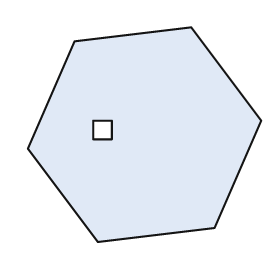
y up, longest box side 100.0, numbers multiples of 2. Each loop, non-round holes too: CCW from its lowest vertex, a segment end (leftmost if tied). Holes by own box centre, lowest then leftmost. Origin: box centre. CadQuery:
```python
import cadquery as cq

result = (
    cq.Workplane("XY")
    .moveTo(-20.0, -46.0)
    .lineTo(30.0, -40.0)
    .lineTo(50.0, 6.0)
    .lineTo(20.0, 46.0)
    .lineTo(-30.0, 40.0)
    .lineTo(-50.0, -6.0)
    .close()
    .moveTo(-22.0, -2.0)
    .lineTo(-14.0, -2.0)
    .lineTo(-14.0, 6.0)
    .lineTo(-22.0, 6.0)
    .close()
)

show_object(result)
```